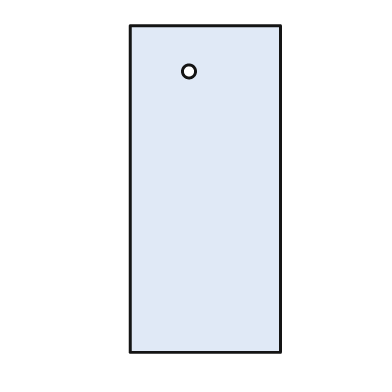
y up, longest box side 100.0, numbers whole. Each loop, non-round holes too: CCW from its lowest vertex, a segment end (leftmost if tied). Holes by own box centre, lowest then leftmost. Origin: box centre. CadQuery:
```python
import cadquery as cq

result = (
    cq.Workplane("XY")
    .moveTo(-23.0, -50.0)
    .lineTo(23.0, -50.0)
    .lineTo(23.0, 50.0)
    .lineTo(-23.0, 50.0)
    .close()
    .moveTo(-5.0, 36.0)
    .circle(2.0)
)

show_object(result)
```